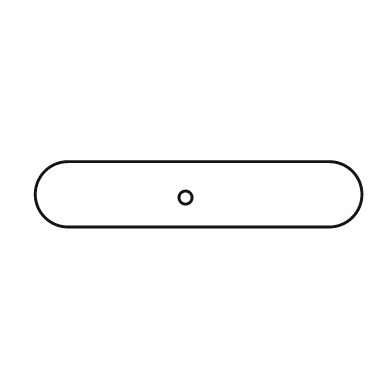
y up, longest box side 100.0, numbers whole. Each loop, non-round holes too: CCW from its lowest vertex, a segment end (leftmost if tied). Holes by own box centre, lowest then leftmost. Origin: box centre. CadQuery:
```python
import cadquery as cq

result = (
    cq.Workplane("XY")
    .moveTo(-40.0, -10.0)
    .lineTo(40.0, -10.0)
    .threePointArc((50.0, 0.0), (40.0, 10.0))
    .lineTo(-40.0, 10.0)
    .threePointArc((-50.0, 0.0), (-40.0, -10.0))
    .close()
    .moveTo(-4.0, -1.0)
    .circle(2.0)
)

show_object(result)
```